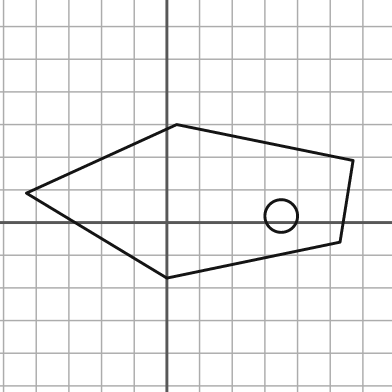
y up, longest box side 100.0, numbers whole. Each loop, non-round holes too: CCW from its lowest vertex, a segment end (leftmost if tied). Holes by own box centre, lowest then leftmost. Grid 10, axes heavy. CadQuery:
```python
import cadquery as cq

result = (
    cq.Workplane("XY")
    .moveTo(0.0, -17.0)
    .lineTo(53.0, -6.0)
    .lineTo(57.0, 19.0)
    .lineTo(3.0, 30.0)
    .lineTo(-43.0, 9.0)
    .close()
    .moveTo(35.0, 2.0)
    .circle(5.0)
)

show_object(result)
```